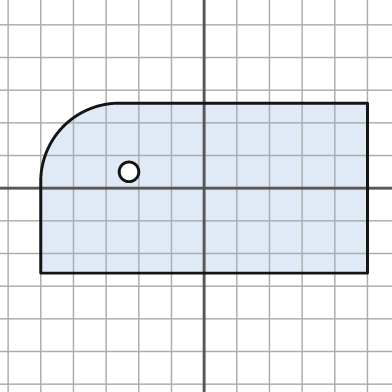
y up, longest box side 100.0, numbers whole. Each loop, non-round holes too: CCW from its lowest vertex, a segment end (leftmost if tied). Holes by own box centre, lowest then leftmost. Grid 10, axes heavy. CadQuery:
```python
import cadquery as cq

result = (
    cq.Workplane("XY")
    .moveTo(-50.0, -26.0)
    .lineTo(50.0, -26.0)
    .lineTo(50.0, 26.0)
    .lineTo(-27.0, 26.0)
    .threePointArc((-43.0, 19.0), (-50.0, 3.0))
    .close()
    .moveTo(-23.0, 5.0)
    .circle(3.0)
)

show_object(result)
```